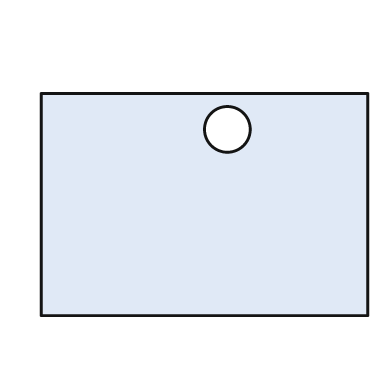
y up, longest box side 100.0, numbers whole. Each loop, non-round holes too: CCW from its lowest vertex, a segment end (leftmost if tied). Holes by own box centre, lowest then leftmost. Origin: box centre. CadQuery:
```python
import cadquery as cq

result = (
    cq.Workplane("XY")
    .moveTo(-50.0, -34.0)
    .lineTo(50.0, -34.0)
    .lineTo(50.0, 34.0)
    .lineTo(-50.0, 34.0)
    .close()
    .moveTo(7.0, 23.0)
    .circle(7.0)
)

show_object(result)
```